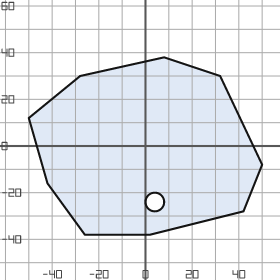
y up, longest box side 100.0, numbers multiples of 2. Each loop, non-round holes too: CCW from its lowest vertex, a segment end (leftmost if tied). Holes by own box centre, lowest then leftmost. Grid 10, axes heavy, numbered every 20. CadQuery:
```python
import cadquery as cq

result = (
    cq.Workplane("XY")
    .moveTo(-26.0, -38.0)
    .lineTo(2.0, -38.0)
    .lineTo(42.0, -28.0)
    .lineTo(50.0, -8.0)
    .lineTo(32.0, 30.0)
    .lineTo(8.0, 38.0)
    .lineTo(-28.0, 30.0)
    .lineTo(-50.0, 12.0)
    .lineTo(-42.0, -16.0)
    .close()
    .moveTo(4.0, -24.0)
    .circle(4.0)
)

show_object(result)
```